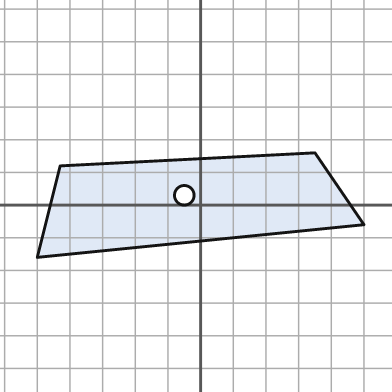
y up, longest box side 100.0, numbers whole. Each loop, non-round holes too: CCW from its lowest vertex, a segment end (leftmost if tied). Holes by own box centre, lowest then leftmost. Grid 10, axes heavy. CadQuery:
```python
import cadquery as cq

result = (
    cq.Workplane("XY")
    .moveTo(-50.0, -16.0)
    .lineTo(50.0, -6.0)
    .lineTo(35.0, 16.0)
    .lineTo(-43.0, 12.0)
    .close()
    .moveTo(-5.0, 3.0)
    .circle(3.0)
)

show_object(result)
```